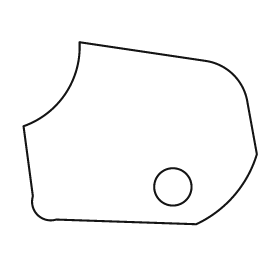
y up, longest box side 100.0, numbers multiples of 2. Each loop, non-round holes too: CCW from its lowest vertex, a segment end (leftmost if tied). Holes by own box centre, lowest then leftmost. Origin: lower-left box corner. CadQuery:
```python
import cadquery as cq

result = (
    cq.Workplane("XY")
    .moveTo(74.0, 0.0)
    .threePointArc((90.0, 12.0), (100.0, 30.0))
    .lineTo(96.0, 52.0)
    .threePointArc((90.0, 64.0), (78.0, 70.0))
    .lineTo(24.0, 78.0)
    .threePointArc((18.0, 56.0), (0.0, 42.0))
    .lineTo(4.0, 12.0)
    .threePointArc((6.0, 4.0), (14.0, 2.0))
    .close()
    .moveTo(64.0, 16.0)
    .circle(8.0)
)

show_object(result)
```